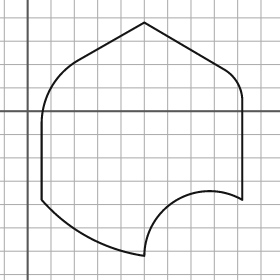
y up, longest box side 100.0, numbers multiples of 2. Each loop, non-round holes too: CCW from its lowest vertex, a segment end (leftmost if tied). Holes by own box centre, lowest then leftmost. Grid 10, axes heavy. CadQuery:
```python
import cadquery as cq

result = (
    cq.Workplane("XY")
    .moveTo(50.0, -62.0)
    .threePointArc((64.0, -38.0), (92.0, -38.0))
    .lineTo(92.0, 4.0)
    .threePointArc((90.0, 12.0), (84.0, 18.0))
    .lineTo(50.0, 38.0)
    .lineTo(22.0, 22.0)
    .threePointArc((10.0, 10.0), (6.0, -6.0))
    .lineTo(6.0, -38.0)
    .threePointArc((26.0, -54.0), (50.0, -62.0))
    .close()
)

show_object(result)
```